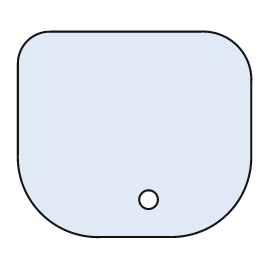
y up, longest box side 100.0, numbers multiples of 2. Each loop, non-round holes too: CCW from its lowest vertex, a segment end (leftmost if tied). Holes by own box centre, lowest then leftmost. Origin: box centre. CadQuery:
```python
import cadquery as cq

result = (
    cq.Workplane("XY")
    .moveTo(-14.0, -44.0)
    .lineTo(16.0, -44.0)
    .threePointArc((40.0, -34.0), (50.0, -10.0))
    .lineTo(50.0, 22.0)
    .threePointArc((44.0, 38.0), (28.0, 44.0))
    .lineTo(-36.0, 44.0)
    .threePointArc((-46.0, 40.0), (-50.0, 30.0))
    .lineTo(-50.0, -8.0)
    .threePointArc((-40.0, -34.0), (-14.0, -44.0))
    .close()
    .moveTo(6.0, -28.0)
    .circle(4.0)
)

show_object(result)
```